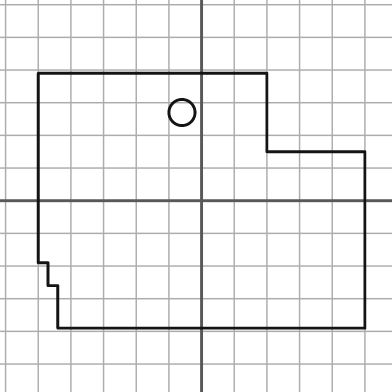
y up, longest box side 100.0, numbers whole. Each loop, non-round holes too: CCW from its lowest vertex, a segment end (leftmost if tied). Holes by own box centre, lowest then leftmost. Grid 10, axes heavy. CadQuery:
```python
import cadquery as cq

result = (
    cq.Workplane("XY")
    .moveTo(-44.0, -39.0)
    .lineTo(50.0, -39.0)
    .lineTo(50.0, 15.0)
    .lineTo(20.0, 15.0)
    .lineTo(20.0, 39.0)
    .lineTo(-50.0, 39.0)
    .lineTo(-50.0, -19.0)
    .lineTo(-47.0, -19.0)
    .lineTo(-47.0, -26.0)
    .lineTo(-44.0, -26.0)
    .close()
    .moveTo(-6.0, 27.0)
    .circle(4.0)
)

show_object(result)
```